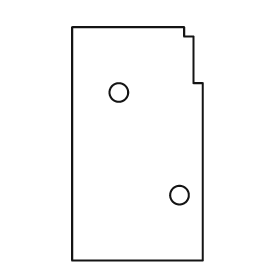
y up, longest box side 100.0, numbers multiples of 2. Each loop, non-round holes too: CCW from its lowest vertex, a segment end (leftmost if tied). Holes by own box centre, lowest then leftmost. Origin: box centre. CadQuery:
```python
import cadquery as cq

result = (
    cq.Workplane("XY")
    .moveTo(-28.0, -50.0)
    .lineTo(28.0, -50.0)
    .lineTo(28.0, 26.0)
    .lineTo(24.0, 26.0)
    .lineTo(24.0, 46.0)
    .lineTo(20.0, 46.0)
    .lineTo(20.0, 50.0)
    .lineTo(-28.0, 50.0)
    .close()
    .moveTo(18.0, -22.0)
    .circle(4.0)
    .moveTo(-8.0, 22.0)
    .circle(4.0)
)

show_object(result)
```